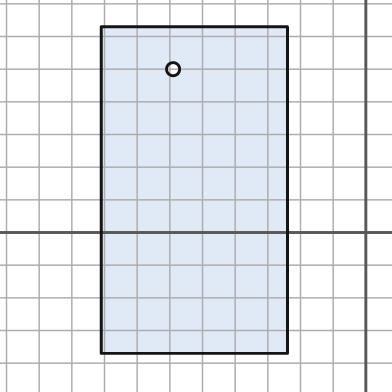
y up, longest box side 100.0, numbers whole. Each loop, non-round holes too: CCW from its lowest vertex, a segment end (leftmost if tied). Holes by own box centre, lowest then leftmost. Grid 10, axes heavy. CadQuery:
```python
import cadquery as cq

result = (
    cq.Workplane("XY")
    .moveTo(-81.0, -37.0)
    .lineTo(-24.0, -37.0)
    .lineTo(-24.0, 63.0)
    .lineTo(-81.0, 63.0)
    .close()
    .moveTo(-59.0, 50.0)
    .circle(2.0)
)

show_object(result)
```